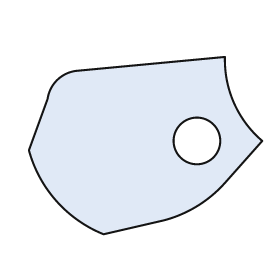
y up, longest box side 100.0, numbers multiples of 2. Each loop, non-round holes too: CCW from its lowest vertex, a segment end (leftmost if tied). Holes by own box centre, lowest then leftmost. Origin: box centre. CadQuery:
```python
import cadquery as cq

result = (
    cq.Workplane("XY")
    .moveTo(-18.0, -38.0)
    .lineTo(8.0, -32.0)
    .threePointArc((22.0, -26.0), (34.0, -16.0))
    .lineTo(50.0, 2.0)
    .threePointArc((38.0, 18.0), (34.0, 38.0))
    .lineTo(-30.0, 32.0)
    .threePointArc((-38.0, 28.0), (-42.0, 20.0))
    .lineTo(-50.0, -2.0)
    .threePointArc((-38.0, -24.0), (-18.0, -38.0))
    .close()
    .moveTo(22.0, 2.0)
    .circle(10.0)
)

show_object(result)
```